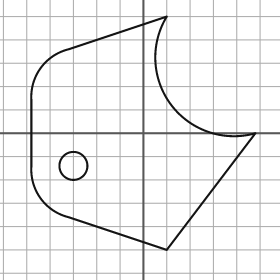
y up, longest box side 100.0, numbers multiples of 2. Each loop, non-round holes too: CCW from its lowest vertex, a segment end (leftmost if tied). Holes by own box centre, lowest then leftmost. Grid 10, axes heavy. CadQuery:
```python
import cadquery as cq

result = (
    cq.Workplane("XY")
    .moveTo(10.0, -50.0)
    .lineTo(48.0, 0.0)
    .threePointArc((12.0, 12.0), (10.0, 50.0))
    .lineTo(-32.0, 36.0)
    .threePointArc((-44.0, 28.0), (-48.0, 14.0))
    .lineTo(-48.0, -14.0)
    .threePointArc((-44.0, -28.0), (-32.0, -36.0))
    .close()
    .moveTo(-30.0, -14.0)
    .circle(6.0)
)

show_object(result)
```